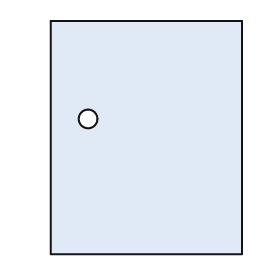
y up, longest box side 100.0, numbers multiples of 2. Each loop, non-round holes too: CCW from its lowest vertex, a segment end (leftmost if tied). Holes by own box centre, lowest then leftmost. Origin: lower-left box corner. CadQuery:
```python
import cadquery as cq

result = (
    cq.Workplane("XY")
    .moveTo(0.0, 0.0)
    .lineTo(82.0, 0.0)
    .lineTo(82.0, 100.0)
    .lineTo(0.0, 100.0)
    .close()
    .moveTo(16.0, 58.0)
    .circle(4.0)
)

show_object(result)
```